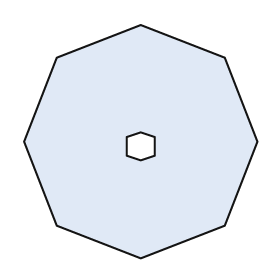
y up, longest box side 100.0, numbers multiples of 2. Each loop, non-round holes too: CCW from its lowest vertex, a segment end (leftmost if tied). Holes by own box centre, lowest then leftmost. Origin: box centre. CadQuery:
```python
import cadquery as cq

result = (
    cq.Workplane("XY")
    .moveTo(0.0, -50.0)
    .lineTo(36.0, -36.0)
    .lineTo(50.0, 0.0)
    .lineTo(36.0, 36.0)
    .lineTo(0.0, 50.0)
    .lineTo(-36.0, 36.0)
    .lineTo(-50.0, 0.0)
    .lineTo(-36.0, -36.0)
    .close()
    .moveTo(0.0, -8.0)
    .lineTo(6.0, -6.0)
    .lineTo(6.0, 2.0)
    .lineTo(0.0, 4.0)
    .lineTo(-6.0, 2.0)
    .lineTo(-6.0, -6.0)
    .close()
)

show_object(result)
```